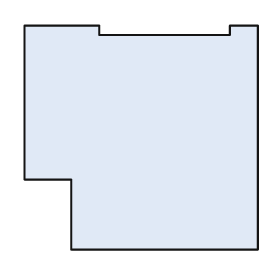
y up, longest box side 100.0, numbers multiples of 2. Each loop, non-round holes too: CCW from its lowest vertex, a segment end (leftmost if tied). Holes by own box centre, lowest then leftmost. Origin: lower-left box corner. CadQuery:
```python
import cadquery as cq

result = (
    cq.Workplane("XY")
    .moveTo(20.0, 0.0)
    .lineTo(100.0, 0.0)
    .lineTo(100.0, 96.0)
    .lineTo(88.0, 96.0)
    .lineTo(88.0, 92.0)
    .lineTo(32.0, 92.0)
    .lineTo(32.0, 96.0)
    .lineTo(0.0, 96.0)
    .lineTo(0.0, 30.0)
    .lineTo(20.0, 30.0)
    .close()
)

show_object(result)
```